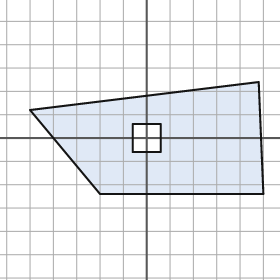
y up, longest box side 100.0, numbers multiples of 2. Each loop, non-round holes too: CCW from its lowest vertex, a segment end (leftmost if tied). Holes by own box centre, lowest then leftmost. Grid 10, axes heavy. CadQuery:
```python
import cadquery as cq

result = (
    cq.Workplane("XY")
    .moveTo(-20.0, -24.0)
    .lineTo(50.0, -24.0)
    .lineTo(48.0, 24.0)
    .lineTo(-50.0, 12.0)
    .close()
    .moveTo(-6.0, -6.0)
    .lineTo(6.0, -6.0)
    .lineTo(6.0, 6.0)
    .lineTo(-6.0, 6.0)
    .close()
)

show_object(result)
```